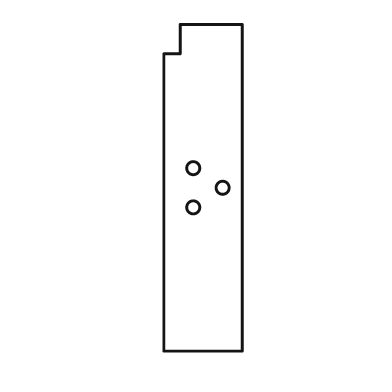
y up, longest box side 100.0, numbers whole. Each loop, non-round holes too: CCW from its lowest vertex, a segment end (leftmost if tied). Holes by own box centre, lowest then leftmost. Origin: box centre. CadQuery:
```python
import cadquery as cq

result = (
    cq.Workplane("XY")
    .moveTo(-12.0, -50.0)
    .lineTo(12.0, -50.0)
    .lineTo(12.0, 50.0)
    .lineTo(-7.0, 50.0)
    .lineTo(-7.0, 41.0)
    .lineTo(-12.0, 41.0)
    .close()
    .moveTo(-3.0, -6.0)
    .circle(2.0)
    .moveTo(6.0, 0.0)
    .circle(2.0)
    .moveTo(-3.0, 6.0)
    .circle(2.0)
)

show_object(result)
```